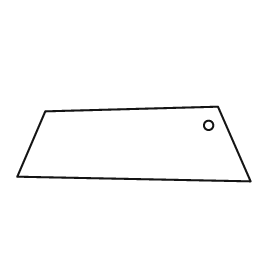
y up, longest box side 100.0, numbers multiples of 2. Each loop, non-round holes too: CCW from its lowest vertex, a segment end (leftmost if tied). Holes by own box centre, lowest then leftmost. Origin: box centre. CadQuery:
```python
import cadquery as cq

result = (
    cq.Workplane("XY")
    .moveTo(50.0, -16.0)
    .lineTo(36.0, 16.0)
    .lineTo(-38.0, 14.0)
    .lineTo(-50.0, -14.0)
    .close()
    .moveTo(32.0, 8.0)
    .circle(2.0)
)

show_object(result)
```